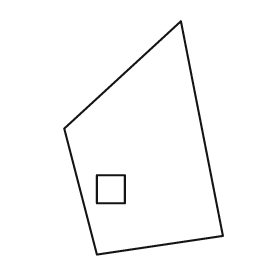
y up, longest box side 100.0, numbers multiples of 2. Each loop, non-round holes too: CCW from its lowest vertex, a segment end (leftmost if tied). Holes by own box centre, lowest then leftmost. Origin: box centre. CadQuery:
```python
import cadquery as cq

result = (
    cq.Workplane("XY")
    .moveTo(-20.0, -50.0)
    .lineTo(34.0, -42.0)
    .lineTo(16.0, 50.0)
    .lineTo(-34.0, 4.0)
    .close()
    .moveTo(-20.0, -28.0)
    .lineTo(-8.0, -28.0)
    .lineTo(-8.0, -16.0)
    .lineTo(-20.0, -16.0)
    .close()
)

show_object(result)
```